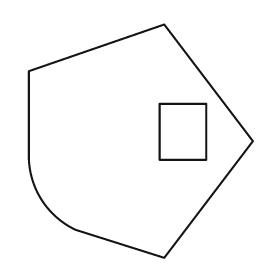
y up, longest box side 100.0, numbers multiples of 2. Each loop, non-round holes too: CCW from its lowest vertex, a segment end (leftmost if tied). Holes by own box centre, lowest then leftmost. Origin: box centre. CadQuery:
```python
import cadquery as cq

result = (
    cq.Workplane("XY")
    .moveTo(10.0, -50.0)
    .lineTo(48.0, 0.0)
    .lineTo(10.0, 50.0)
    .lineTo(-48.0, 30.0)
    .lineTo(-48.0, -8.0)
    .threePointArc((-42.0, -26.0), (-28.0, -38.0))
    .close()
    .moveTo(8.0, -8.0)
    .lineTo(28.0, -8.0)
    .lineTo(28.0, 16.0)
    .lineTo(8.0, 16.0)
    .close()
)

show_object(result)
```